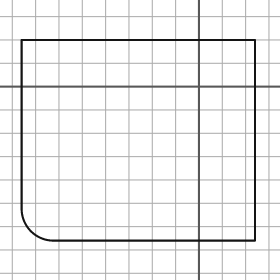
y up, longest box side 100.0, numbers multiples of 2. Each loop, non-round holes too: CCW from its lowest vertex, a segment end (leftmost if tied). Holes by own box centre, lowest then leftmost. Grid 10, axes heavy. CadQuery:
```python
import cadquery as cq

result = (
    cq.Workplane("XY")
    .moveTo(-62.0, -66.0)
    .lineTo(24.0, -66.0)
    .lineTo(24.0, 20.0)
    .lineTo(-76.0, 20.0)
    .lineTo(-76.0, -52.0)
    .threePointArc((-72.0, -62.0), (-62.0, -66.0))
    .close()
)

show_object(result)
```